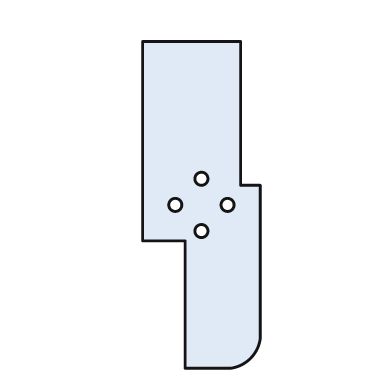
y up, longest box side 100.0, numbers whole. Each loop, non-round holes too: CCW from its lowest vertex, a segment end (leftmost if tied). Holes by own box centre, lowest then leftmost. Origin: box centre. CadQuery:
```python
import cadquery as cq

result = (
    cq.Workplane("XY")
    .moveTo(-5.0, -50.0)
    .lineTo(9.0, -50.0)
    .threePointArc((15.0, -47.0), (18.0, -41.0))
    .lineTo(18.0, 6.0)
    .lineTo(12.0, 6.0)
    .lineTo(12.0, 50.0)
    .lineTo(-18.0, 50.0)
    .lineTo(-18.0, -11.0)
    .lineTo(-5.0, -11.0)
    .close()
    .moveTo(0.0, -8.0)
    .circle(2.0)
    .moveTo(-8.0, 0.0)
    .circle(2.0)
    .moveTo(8.0, 0.0)
    .circle(2.0)
    .moveTo(0.0, 8.0)
    .circle(2.0)
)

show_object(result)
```